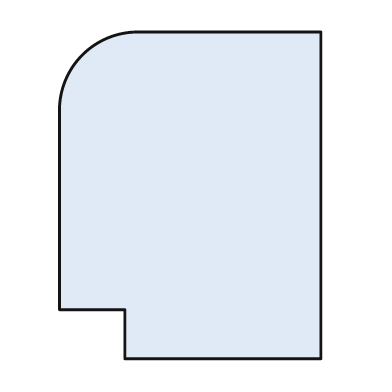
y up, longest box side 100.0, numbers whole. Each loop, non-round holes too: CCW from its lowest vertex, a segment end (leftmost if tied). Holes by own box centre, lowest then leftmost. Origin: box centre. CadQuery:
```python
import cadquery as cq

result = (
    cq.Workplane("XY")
    .moveTo(-20.0, -50.0)
    .lineTo(40.0, -50.0)
    .lineTo(40.0, 50.0)
    .lineTo(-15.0, 50.0)
    .threePointArc((-33.0, 43.0), (-40.0, 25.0))
    .lineTo(-40.0, -35.0)
    .lineTo(-20.0, -35.0)
    .close()
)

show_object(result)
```